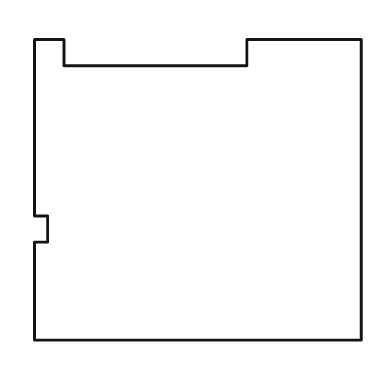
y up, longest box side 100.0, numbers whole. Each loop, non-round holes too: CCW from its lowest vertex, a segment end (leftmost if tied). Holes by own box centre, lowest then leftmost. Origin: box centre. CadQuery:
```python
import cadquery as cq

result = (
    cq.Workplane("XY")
    .moveTo(-50.0, -46.0)
    .lineTo(50.0, -46.0)
    .lineTo(50.0, 46.0)
    .lineTo(15.0, 46.0)
    .lineTo(15.0, 38.0)
    .lineTo(-41.0, 38.0)
    .lineTo(-41.0, 46.0)
    .lineTo(-50.0, 46.0)
    .lineTo(-50.0, -8.0)
    .lineTo(-46.0, -8.0)
    .lineTo(-46.0, -16.0)
    .lineTo(-50.0, -16.0)
    .close()
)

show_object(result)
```